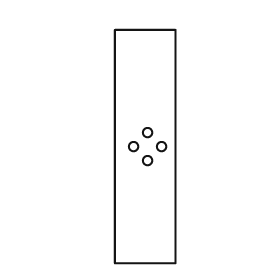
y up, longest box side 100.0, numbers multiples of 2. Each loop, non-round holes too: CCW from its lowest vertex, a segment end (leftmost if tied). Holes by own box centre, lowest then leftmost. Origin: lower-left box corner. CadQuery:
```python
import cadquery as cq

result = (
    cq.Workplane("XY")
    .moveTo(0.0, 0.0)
    .lineTo(26.0, 0.0)
    .lineTo(26.0, 100.0)
    .lineTo(0.0, 100.0)
    .close()
    .moveTo(14.0, 44.0)
    .circle(2.0)
    .moveTo(8.0, 50.0)
    .circle(2.0)
    .moveTo(20.0, 50.0)
    .circle(2.0)
    .moveTo(14.0, 56.0)
    .circle(2.0)
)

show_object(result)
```